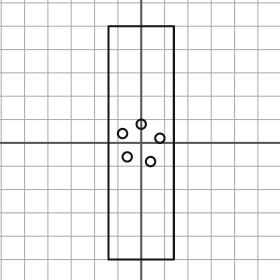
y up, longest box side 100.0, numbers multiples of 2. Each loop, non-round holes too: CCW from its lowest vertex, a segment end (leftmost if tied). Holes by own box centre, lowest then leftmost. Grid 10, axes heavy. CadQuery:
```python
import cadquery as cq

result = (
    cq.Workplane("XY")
    .moveTo(-14.0, -50.0)
    .lineTo(14.0, -50.0)
    .lineTo(14.0, 50.0)
    .lineTo(-14.0, 50.0)
    .close()
    .moveTo(4.0, -8.0)
    .circle(2.0)
    .moveTo(-6.0, -6.0)
    .circle(2.0)
    .moveTo(8.0, 2.0)
    .circle(2.0)
    .moveTo(-8.0, 4.0)
    .circle(2.0)
    .moveTo(0.0, 8.0)
    .circle(2.0)
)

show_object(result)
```